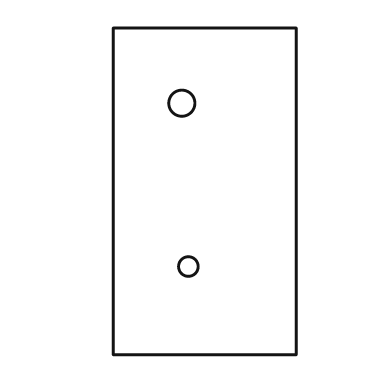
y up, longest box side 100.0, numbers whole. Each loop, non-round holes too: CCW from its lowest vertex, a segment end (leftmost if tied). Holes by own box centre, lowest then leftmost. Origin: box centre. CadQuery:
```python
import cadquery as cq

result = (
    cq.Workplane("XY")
    .moveTo(-28.0, -50.0)
    .lineTo(28.0, -50.0)
    .lineTo(28.0, 50.0)
    .lineTo(-28.0, 50.0)
    .close()
    .moveTo(-5.0, -23.0)
    .circle(3.0)
    .moveTo(-7.0, 27.0)
    .circle(4.0)
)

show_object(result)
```